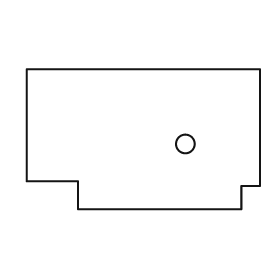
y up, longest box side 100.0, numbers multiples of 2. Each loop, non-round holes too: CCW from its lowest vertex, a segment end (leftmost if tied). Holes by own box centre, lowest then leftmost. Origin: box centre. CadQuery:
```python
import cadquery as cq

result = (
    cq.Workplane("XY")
    .moveTo(-28.0, -30.0)
    .lineTo(42.0, -30.0)
    .lineTo(42.0, -20.0)
    .lineTo(50.0, -20.0)
    .lineTo(50.0, 30.0)
    .lineTo(-50.0, 30.0)
    .lineTo(-50.0, -18.0)
    .lineTo(-28.0, -18.0)
    .close()
    .moveTo(18.0, -2.0)
    .circle(4.0)
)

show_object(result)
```